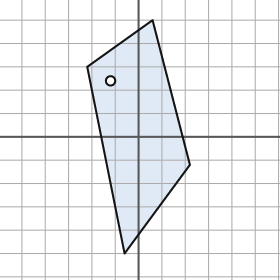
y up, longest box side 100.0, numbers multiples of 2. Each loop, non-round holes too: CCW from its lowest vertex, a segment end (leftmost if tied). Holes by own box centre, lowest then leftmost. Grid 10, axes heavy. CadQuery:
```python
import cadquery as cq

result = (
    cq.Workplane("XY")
    .moveTo(-6.0, -50.0)
    .lineTo(22.0, -12.0)
    .lineTo(6.0, 50.0)
    .lineTo(-22.0, 30.0)
    .close()
    .moveTo(-12.0, 24.0)
    .circle(2.0)
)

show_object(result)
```